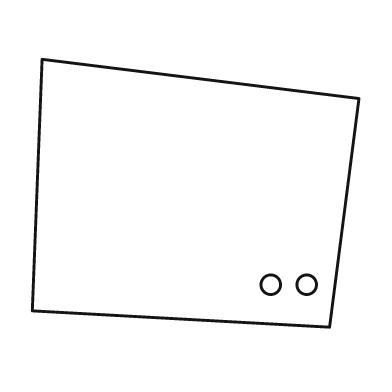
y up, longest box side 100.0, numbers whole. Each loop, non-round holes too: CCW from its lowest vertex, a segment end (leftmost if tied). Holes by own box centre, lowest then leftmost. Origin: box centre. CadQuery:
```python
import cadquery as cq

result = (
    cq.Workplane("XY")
    .moveTo(41.0, -41.0)
    .lineTo(50.0, 29.0)
    .lineTo(-47.0, 41.0)
    .lineTo(-50.0, -36.0)
    .close()
    .moveTo(23.0, -28.0)
    .circle(3.0)
    .moveTo(34.0, -28.0)
    .circle(3.0)
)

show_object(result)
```